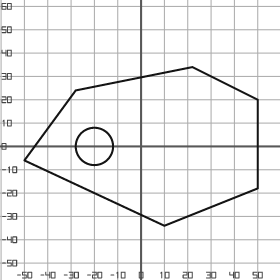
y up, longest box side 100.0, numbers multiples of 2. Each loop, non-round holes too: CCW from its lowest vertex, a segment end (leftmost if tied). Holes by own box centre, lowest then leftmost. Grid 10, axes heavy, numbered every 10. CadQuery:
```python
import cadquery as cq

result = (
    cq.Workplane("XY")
    .moveTo(10.0, -34.0)
    .lineTo(50.0, -18.0)
    .lineTo(50.0, 20.0)
    .lineTo(22.0, 34.0)
    .lineTo(-28.0, 24.0)
    .lineTo(-50.0, -6.0)
    .close()
    .moveTo(-20.0, 0.0)
    .circle(8.0)
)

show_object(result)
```